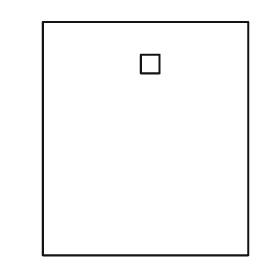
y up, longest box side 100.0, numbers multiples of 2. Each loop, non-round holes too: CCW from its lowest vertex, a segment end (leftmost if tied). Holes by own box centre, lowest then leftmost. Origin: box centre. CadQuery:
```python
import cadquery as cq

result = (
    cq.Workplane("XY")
    .moveTo(-44.0, -50.0)
    .lineTo(44.0, -50.0)
    .lineTo(44.0, 50.0)
    .lineTo(-44.0, 50.0)
    .close()
    .moveTo(-2.0, 28.0)
    .lineTo(6.0, 28.0)
    .lineTo(6.0, 36.0)
    .lineTo(-2.0, 36.0)
    .close()
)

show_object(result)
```